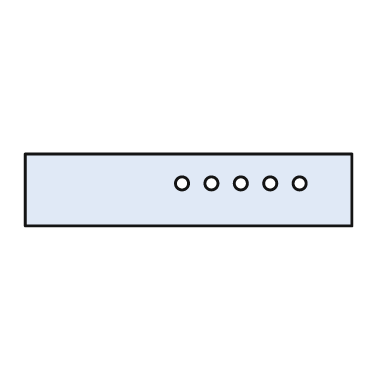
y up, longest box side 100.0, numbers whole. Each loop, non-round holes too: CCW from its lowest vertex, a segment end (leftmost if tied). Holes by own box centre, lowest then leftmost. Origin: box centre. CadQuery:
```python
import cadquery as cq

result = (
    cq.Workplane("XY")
    .moveTo(-50.0, -11.0)
    .lineTo(50.0, -11.0)
    .lineTo(50.0, 11.0)
    .lineTo(-50.0, 11.0)
    .close()
    .moveTo(-2.0, 2.0)
    .circle(2.0)
    .moveTo(7.0, 2.0)
    .circle(2.0)
    .moveTo(16.0, 2.0)
    .circle(2.0)
    .moveTo(25.0, 2.0)
    .circle(2.0)
    .moveTo(34.0, 2.0)
    .circle(2.0)
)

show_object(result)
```